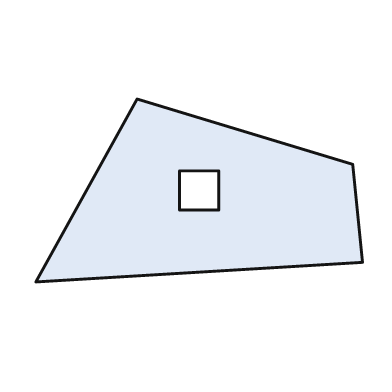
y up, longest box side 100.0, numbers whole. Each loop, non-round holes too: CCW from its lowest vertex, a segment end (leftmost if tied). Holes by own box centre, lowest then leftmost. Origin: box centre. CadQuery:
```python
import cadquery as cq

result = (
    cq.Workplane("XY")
    .moveTo(-50.0, -28.0)
    .lineTo(50.0, -22.0)
    .lineTo(47.0, 8.0)
    .lineTo(-19.0, 28.0)
    .close()
    .moveTo(-6.0, -6.0)
    .lineTo(6.0, -6.0)
    .lineTo(6.0, 6.0)
    .lineTo(-6.0, 6.0)
    .close()
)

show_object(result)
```